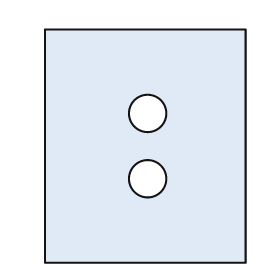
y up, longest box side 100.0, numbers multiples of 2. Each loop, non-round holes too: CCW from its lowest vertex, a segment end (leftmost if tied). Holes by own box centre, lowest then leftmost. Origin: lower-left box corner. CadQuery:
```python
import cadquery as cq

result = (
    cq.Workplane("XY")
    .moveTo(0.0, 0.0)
    .lineTo(86.0, 0.0)
    .lineTo(86.0, 100.0)
    .lineTo(0.0, 100.0)
    .close()
    .moveTo(44.0, 36.0)
    .circle(8.0)
    .moveTo(44.0, 64.0)
    .circle(8.0)
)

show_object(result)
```